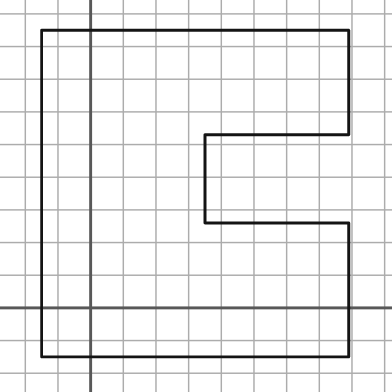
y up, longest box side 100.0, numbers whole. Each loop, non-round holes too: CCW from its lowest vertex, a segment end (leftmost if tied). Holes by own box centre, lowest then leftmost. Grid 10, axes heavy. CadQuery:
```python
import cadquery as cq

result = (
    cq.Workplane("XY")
    .moveTo(-15.0, -15.0)
    .lineTo(79.0, -15.0)
    .lineTo(79.0, 26.0)
    .lineTo(35.0, 26.0)
    .lineTo(35.0, 53.0)
    .lineTo(79.0, 53.0)
    .lineTo(79.0, 85.0)
    .lineTo(-15.0, 85.0)
    .close()
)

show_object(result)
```